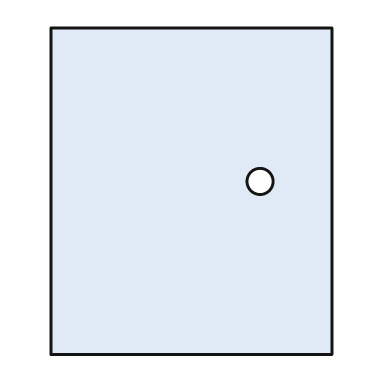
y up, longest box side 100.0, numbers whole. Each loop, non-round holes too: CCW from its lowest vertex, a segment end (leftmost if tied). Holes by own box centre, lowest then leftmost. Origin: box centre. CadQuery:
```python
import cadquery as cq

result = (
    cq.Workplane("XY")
    .moveTo(-43.0, -50.0)
    .lineTo(43.0, -50.0)
    .lineTo(43.0, 50.0)
    .lineTo(-43.0, 50.0)
    .close()
    .moveTo(21.0, 3.0)
    .circle(4.0)
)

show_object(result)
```